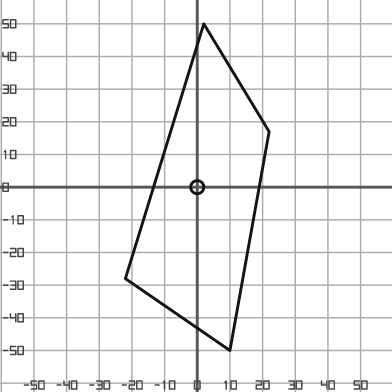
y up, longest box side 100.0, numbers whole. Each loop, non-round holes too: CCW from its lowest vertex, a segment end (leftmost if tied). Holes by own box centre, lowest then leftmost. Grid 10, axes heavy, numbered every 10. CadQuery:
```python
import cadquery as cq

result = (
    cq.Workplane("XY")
    .moveTo(10.0, -50.0)
    .lineTo(22.0, 17.0)
    .lineTo(2.0, 50.0)
    .lineTo(-22.0, -28.0)
    .close()
    .moveTo(0.0, 0.0)
    .circle(2.0)
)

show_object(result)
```